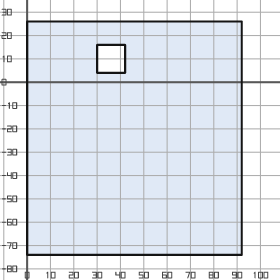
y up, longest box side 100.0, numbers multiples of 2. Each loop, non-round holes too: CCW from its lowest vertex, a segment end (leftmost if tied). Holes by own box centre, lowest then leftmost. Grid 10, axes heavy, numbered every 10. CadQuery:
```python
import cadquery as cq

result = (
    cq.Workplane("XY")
    .moveTo(0.0, -74.0)
    .lineTo(92.0, -74.0)
    .lineTo(92.0, 26.0)
    .lineTo(0.0, 26.0)
    .close()
    .moveTo(30.0, 4.0)
    .lineTo(42.0, 4.0)
    .lineTo(42.0, 16.0)
    .lineTo(30.0, 16.0)
    .close()
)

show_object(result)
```